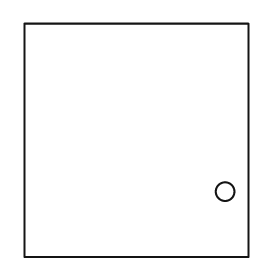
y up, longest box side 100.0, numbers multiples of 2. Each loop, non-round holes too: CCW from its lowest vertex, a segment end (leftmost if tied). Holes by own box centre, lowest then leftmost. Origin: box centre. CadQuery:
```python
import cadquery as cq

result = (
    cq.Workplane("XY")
    .moveTo(-48.0, -50.0)
    .lineTo(48.0, -50.0)
    .lineTo(48.0, 50.0)
    .lineTo(-48.0, 50.0)
    .close()
    .moveTo(38.0, -22.0)
    .circle(4.0)
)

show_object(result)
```